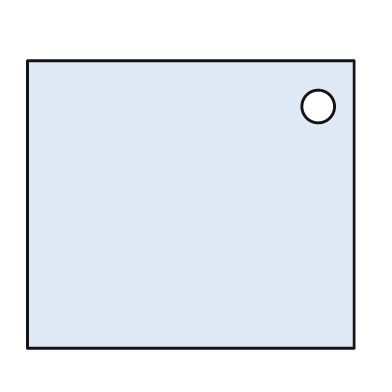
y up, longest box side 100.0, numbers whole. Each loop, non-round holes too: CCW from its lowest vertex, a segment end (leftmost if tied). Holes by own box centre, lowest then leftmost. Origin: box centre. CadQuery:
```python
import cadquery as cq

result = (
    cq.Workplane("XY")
    .moveTo(-50.0, -44.0)
    .lineTo(50.0, -44.0)
    .lineTo(50.0, 44.0)
    .lineTo(-50.0, 44.0)
    .close()
    .moveTo(39.0, 30.0)
    .circle(5.0)
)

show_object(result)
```